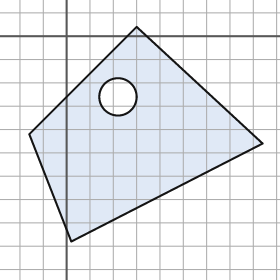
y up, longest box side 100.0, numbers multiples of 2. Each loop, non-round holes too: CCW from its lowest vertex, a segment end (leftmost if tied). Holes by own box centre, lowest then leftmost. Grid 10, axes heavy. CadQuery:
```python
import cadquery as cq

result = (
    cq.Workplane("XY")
    .moveTo(2.0, -88.0)
    .lineTo(84.0, -46.0)
    .lineTo(30.0, 4.0)
    .lineTo(-16.0, -42.0)
    .close()
    .moveTo(22.0, -26.0)
    .circle(8.0)
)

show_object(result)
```